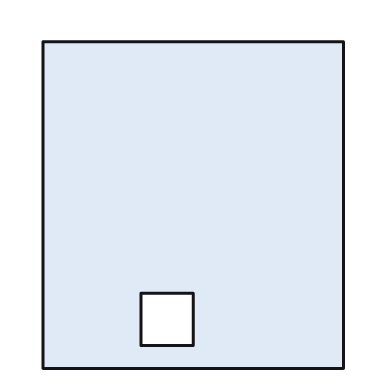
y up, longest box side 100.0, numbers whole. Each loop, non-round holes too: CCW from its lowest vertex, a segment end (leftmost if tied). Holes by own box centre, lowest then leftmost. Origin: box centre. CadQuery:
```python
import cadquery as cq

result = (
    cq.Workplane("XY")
    .moveTo(-46.0, -50.0)
    .lineTo(46.0, -50.0)
    .lineTo(46.0, 50.0)
    .lineTo(-46.0, 50.0)
    .close()
    .moveTo(-16.0, -43.0)
    .lineTo(0.0, -43.0)
    .lineTo(0.0, -27.0)
    .lineTo(-16.0, -27.0)
    .close()
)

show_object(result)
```